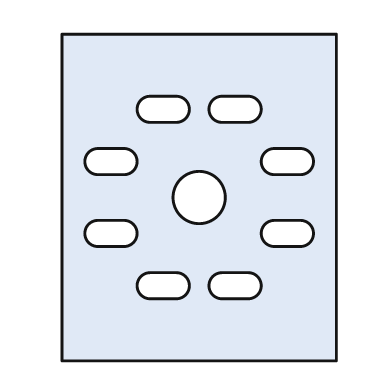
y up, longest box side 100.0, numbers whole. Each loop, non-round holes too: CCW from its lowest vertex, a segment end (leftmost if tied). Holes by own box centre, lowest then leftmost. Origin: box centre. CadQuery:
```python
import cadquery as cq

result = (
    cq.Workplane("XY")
    .moveTo(-42.0, -50.0)
    .lineTo(42.0, -50.0)
    .lineTo(42.0, 50.0)
    .lineTo(-42.0, 50.0)
    .close()
    .moveTo(-15.0, -31.0)
    .lineTo(-7.0, -31.0)
    .threePointArc((-3.0, -27.0), (-7.0, -23.0))
    .lineTo(-15.0, -23.0)
    .threePointArc((-19.0, -27.0), (-15.0, -31.0))
    .close()
    .moveTo(7.0, -31.0)
    .lineTo(15.0, -31.0)
    .threePointArc((19.0, -27.0), (15.0, -23.0))
    .lineTo(7.0, -23.0)
    .threePointArc((3.0, -27.0), (7.0, -31.0))
    .close()
    .moveTo(-31.0, -15.0)
    .lineTo(-23.0, -15.0)
    .threePointArc((-19.0, -11.0), (-23.0, -7.0))
    .lineTo(-31.0, -7.0)
    .threePointArc((-35.0, -11.0), (-31.0, -15.0))
    .close()
    .moveTo(23.0, -15.0)
    .lineTo(31.0, -15.0)
    .threePointArc((35.0, -11.0), (31.0, -7.0))
    .lineTo(23.0, -7.0)
    .threePointArc((19.0, -11.0), (23.0, -15.0))
    .close()
    .moveTo(0.0, 0.0)
    .circle(8.0)
    .moveTo(-31.0, 7.0)
    .lineTo(-23.0, 7.0)
    .threePointArc((-19.0, 11.0), (-23.0, 15.0))
    .lineTo(-31.0, 15.0)
    .threePointArc((-35.0, 11.0), (-31.0, 7.0))
    .close()
    .moveTo(23.0, 7.0)
    .lineTo(31.0, 7.0)
    .threePointArc((35.0, 11.0), (31.0, 15.0))
    .lineTo(23.0, 15.0)
    .threePointArc((19.0, 11.0), (23.0, 7.0))
    .close()
    .moveTo(-15.0, 23.0)
    .lineTo(-7.0, 23.0)
    .threePointArc((-3.0, 27.0), (-7.0, 31.0))
    .lineTo(-15.0, 31.0)
    .threePointArc((-19.0, 27.0), (-15.0, 23.0))
    .close()
    .moveTo(7.0, 23.0)
    .lineTo(15.0, 23.0)
    .threePointArc((19.0, 27.0), (15.0, 31.0))
    .lineTo(7.0, 31.0)
    .threePointArc((3.0, 27.0), (7.0, 23.0))
    .close()
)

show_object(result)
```